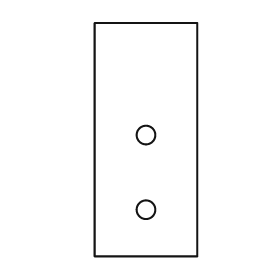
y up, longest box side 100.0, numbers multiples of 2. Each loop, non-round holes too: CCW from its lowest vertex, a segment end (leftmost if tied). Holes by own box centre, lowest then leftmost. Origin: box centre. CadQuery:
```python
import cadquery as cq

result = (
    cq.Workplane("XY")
    .moveTo(-22.0, -50.0)
    .lineTo(22.0, -50.0)
    .lineTo(22.0, 50.0)
    .lineTo(-22.0, 50.0)
    .close()
    .moveTo(0.0, -30.0)
    .circle(4.0)
    .moveTo(0.0, 2.0)
    .circle(4.0)
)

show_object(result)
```